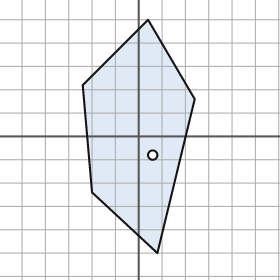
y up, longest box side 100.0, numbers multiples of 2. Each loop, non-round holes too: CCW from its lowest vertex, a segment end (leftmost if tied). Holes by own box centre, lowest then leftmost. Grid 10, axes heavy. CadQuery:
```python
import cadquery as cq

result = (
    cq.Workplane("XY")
    .moveTo(8.0, -50.0)
    .lineTo(24.0, 16.0)
    .lineTo(4.0, 50.0)
    .lineTo(-24.0, 22.0)
    .lineTo(-20.0, -24.0)
    .close()
    .moveTo(6.0, -8.0)
    .circle(2.0)
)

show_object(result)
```